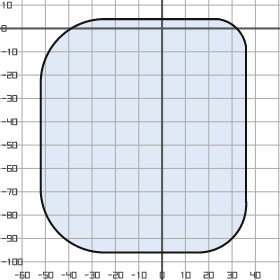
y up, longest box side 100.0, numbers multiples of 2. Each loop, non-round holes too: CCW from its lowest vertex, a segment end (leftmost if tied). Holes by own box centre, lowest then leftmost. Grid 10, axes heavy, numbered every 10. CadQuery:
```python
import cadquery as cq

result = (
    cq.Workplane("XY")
    .moveTo(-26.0, -96.0)
    .lineTo(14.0, -96.0)
    .threePointArc((30.0, -90.0), (36.0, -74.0))
    .lineTo(36.0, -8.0)
    .threePointArc((32.0, 0.0), (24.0, 4.0))
    .lineTo(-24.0, 4.0)
    .threePointArc((-44.0, -4.0), (-52.0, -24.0))
    .lineTo(-52.0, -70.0)
    .threePointArc((-44.0, -88.0), (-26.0, -96.0))
    .close()
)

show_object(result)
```